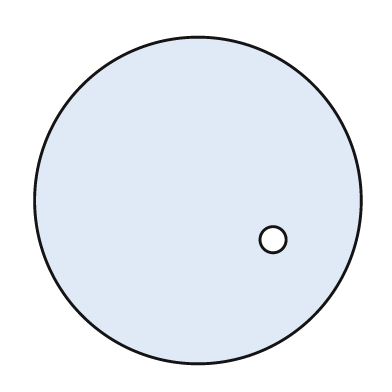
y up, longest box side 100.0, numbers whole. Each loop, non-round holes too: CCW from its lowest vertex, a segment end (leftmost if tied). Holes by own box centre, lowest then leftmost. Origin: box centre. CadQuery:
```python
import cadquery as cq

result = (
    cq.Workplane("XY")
    .moveTo(0.0, 0.0)
    .circle(50.0)
    .moveTo(23.0, -12.0)
    .circle(4.0)
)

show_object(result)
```